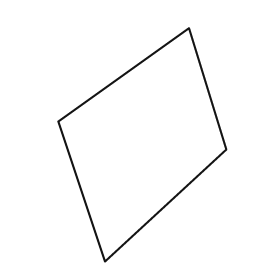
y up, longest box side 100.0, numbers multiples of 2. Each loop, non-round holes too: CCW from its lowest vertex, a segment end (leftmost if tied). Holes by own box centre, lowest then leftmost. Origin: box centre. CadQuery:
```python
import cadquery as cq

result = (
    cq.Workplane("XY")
    .moveTo(-16.0, -50.0)
    .lineTo(36.0, -2.0)
    .lineTo(20.0, 50.0)
    .lineTo(-36.0, 10.0)
    .close()
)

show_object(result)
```